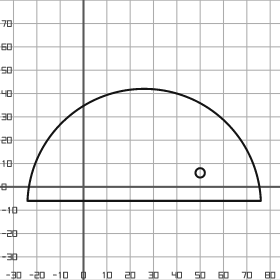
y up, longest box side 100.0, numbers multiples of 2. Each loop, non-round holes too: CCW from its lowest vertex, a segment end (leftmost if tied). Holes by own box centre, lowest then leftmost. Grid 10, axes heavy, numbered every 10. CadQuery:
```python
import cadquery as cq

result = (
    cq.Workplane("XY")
    .moveTo(-24.0, -6.0)
    .lineTo(76.0, -6.0)
    .threePointArc((26.0, 42.0), (-24.0, -6.0))
    .close()
    .moveTo(50.0, 6.0)
    .circle(2.0)
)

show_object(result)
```